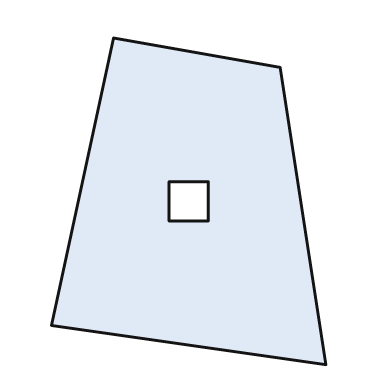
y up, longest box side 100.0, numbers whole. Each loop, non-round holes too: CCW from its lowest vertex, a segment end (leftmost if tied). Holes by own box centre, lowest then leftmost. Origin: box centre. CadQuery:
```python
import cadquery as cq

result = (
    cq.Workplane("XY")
    .moveTo(42.0, -50.0)
    .lineTo(28.0, 41.0)
    .lineTo(-23.0, 50.0)
    .lineTo(-42.0, -38.0)
    .close()
    .moveTo(-6.0, -6.0)
    .lineTo(6.0, -6.0)
    .lineTo(6.0, 6.0)
    .lineTo(-6.0, 6.0)
    .close()
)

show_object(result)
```